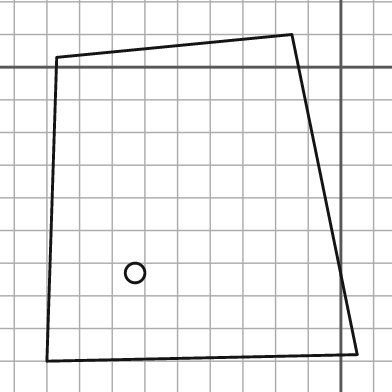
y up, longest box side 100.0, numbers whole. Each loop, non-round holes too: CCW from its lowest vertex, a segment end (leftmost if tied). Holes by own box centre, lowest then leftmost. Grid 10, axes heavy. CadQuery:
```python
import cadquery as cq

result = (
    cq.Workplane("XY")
    .moveTo(-90.0, -90.0)
    .lineTo(5.0, -88.0)
    .lineTo(-15.0, 10.0)
    .lineTo(-87.0, 3.0)
    .close()
    .moveTo(-63.0, -63.0)
    .circle(3.0)
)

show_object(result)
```